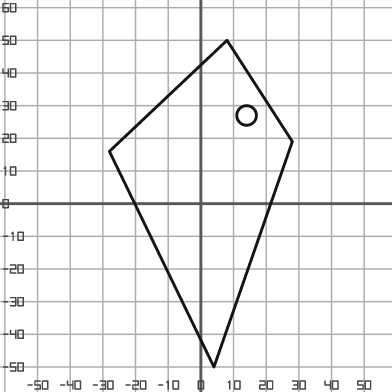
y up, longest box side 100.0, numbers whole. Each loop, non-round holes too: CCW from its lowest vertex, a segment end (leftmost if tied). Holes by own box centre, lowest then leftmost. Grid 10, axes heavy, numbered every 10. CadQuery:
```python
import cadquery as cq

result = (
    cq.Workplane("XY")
    .moveTo(4.0, -50.0)
    .lineTo(28.0, 19.0)
    .lineTo(8.0, 50.0)
    .lineTo(-28.0, 16.0)
    .close()
    .moveTo(14.0, 27.0)
    .circle(3.0)
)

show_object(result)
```